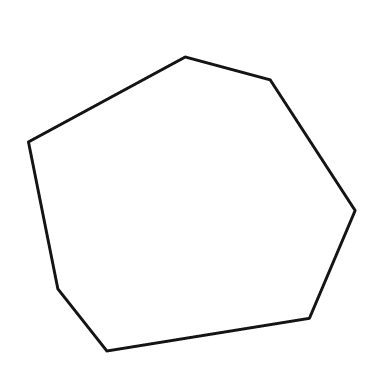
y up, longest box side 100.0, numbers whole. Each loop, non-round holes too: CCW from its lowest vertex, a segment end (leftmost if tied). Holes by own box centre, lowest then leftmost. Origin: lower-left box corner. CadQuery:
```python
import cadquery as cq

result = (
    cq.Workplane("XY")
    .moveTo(24.0, 0.0)
    .lineTo(86.0, 10.0)
    .lineTo(100.0, 43.0)
    .lineTo(74.0, 83.0)
    .lineTo(48.0, 90.0)
    .lineTo(0.0, 64.0)
    .lineTo(9.0, 19.0)
    .close()
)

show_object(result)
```